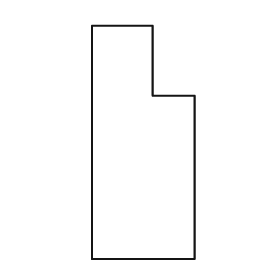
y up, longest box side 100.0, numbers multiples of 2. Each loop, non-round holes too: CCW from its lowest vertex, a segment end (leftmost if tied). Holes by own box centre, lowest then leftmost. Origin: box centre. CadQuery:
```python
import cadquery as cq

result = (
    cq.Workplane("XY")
    .moveTo(-22.0, -50.0)
    .lineTo(22.0, -50.0)
    .lineTo(22.0, 20.0)
    .lineTo(4.0, 20.0)
    .lineTo(4.0, 50.0)
    .lineTo(-22.0, 50.0)
    .close()
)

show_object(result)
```